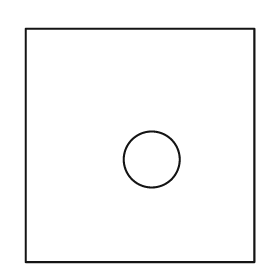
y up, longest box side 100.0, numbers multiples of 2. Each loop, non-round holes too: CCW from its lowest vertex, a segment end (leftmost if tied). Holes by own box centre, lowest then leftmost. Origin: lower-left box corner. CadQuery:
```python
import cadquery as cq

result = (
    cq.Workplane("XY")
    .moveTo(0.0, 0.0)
    .lineTo(98.0, 0.0)
    .lineTo(98.0, 100.0)
    .lineTo(0.0, 100.0)
    .close()
    .moveTo(54.0, 44.0)
    .circle(12.0)
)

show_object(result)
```